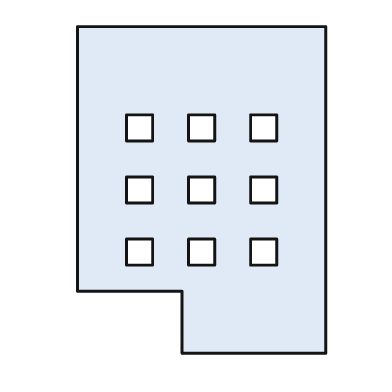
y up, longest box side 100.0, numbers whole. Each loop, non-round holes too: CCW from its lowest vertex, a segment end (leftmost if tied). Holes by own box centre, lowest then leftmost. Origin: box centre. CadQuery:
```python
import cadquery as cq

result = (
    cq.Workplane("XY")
    .moveTo(-6.0, -50.0)
    .lineTo(38.0, -50.0)
    .lineTo(38.0, 50.0)
    .lineTo(-38.0, 50.0)
    .lineTo(-38.0, -31.0)
    .lineTo(-6.0, -31.0)
    .close()
    .moveTo(-23.0, -23.0)
    .lineTo(-15.0, -23.0)
    .lineTo(-15.0, -15.0)
    .lineTo(-23.0, -15.0)
    .close()
    .moveTo(-4.0, -23.0)
    .lineTo(4.0, -23.0)
    .lineTo(4.0, -15.0)
    .lineTo(-4.0, -15.0)
    .close()
    .moveTo(15.0, -23.0)
    .lineTo(23.0, -23.0)
    .lineTo(23.0, -15.0)
    .lineTo(15.0, -15.0)
    .close()
    .moveTo(-23.0, -4.0)
    .lineTo(-15.0, -4.0)
    .lineTo(-15.0, 4.0)
    .lineTo(-23.0, 4.0)
    .close()
    .moveTo(-4.0, -4.0)
    .lineTo(4.0, -4.0)
    .lineTo(4.0, 4.0)
    .lineTo(-4.0, 4.0)
    .close()
    .moveTo(15.0, -4.0)
    .lineTo(23.0, -4.0)
    .lineTo(23.0, 4.0)
    .lineTo(15.0, 4.0)
    .close()
    .moveTo(-23.0, 15.0)
    .lineTo(-15.0, 15.0)
    .lineTo(-15.0, 23.0)
    .lineTo(-23.0, 23.0)
    .close()
    .moveTo(-4.0, 15.0)
    .lineTo(4.0, 15.0)
    .lineTo(4.0, 23.0)
    .lineTo(-4.0, 23.0)
    .close()
    .moveTo(15.0, 15.0)
    .lineTo(23.0, 15.0)
    .lineTo(23.0, 23.0)
    .lineTo(15.0, 23.0)
    .close()
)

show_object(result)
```